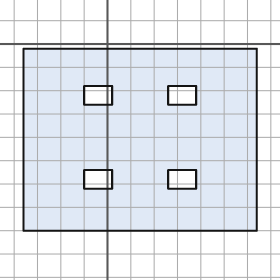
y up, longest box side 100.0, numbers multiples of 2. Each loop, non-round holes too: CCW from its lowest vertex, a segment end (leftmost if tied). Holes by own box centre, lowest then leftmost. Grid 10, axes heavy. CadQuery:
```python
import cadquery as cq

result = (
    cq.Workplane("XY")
    .moveTo(-36.0, -80.0)
    .lineTo(64.0, -80.0)
    .lineTo(64.0, -2.0)
    .lineTo(-36.0, -2.0)
    .close()
    .moveTo(-10.0, -62.0)
    .lineTo(2.0, -62.0)
    .lineTo(2.0, -54.0)
    .lineTo(-10.0, -54.0)
    .close()
    .moveTo(26.0, -62.0)
    .lineTo(38.0, -62.0)
    .lineTo(38.0, -54.0)
    .lineTo(26.0, -54.0)
    .close()
    .moveTo(-10.0, -26.0)
    .lineTo(2.0, -26.0)
    .lineTo(2.0, -18.0)
    .lineTo(-10.0, -18.0)
    .close()
    .moveTo(26.0, -26.0)
    .lineTo(38.0, -26.0)
    .lineTo(38.0, -18.0)
    .lineTo(26.0, -18.0)
    .close()
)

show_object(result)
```